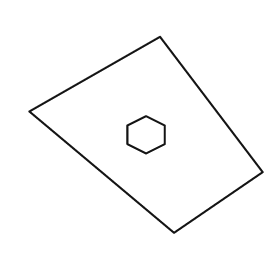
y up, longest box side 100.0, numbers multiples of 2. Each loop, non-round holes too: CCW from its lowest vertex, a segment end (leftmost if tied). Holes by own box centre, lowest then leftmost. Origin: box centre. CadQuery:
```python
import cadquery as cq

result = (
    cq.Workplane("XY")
    .moveTo(12.0, -42.0)
    .lineTo(50.0, -16.0)
    .lineTo(6.0, 42.0)
    .lineTo(-50.0, 10.0)
    .close()
    .moveTo(0.0, -8.0)
    .lineTo(8.0, -4.0)
    .lineTo(8.0, 4.0)
    .lineTo(0.0, 8.0)
    .lineTo(-8.0, 4.0)
    .lineTo(-8.0, -4.0)
    .close()
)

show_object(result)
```